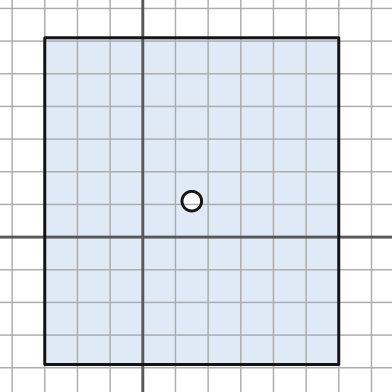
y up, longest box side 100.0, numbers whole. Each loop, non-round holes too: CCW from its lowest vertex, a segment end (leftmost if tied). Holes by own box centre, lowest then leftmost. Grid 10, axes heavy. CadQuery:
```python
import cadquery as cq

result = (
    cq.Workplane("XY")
    .moveTo(-30.0, -39.0)
    .lineTo(60.0, -39.0)
    .lineTo(60.0, 61.0)
    .lineTo(-30.0, 61.0)
    .close()
    .moveTo(15.0, 11.0)
    .circle(3.0)
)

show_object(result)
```